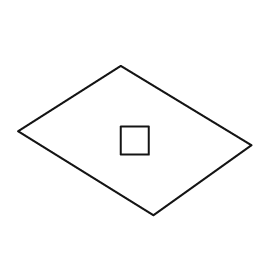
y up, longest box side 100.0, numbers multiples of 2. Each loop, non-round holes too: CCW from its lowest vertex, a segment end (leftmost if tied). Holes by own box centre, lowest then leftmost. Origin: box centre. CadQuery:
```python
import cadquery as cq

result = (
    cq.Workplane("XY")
    .moveTo(8.0, -32.0)
    .lineTo(50.0, -2.0)
    .lineTo(-6.0, 32.0)
    .lineTo(-50.0, 4.0)
    .close()
    .moveTo(-6.0, -6.0)
    .lineTo(6.0, -6.0)
    .lineTo(6.0, 6.0)
    .lineTo(-6.0, 6.0)
    .close()
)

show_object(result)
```